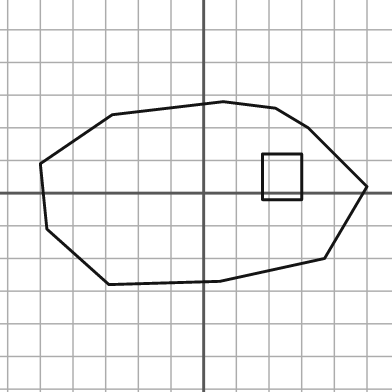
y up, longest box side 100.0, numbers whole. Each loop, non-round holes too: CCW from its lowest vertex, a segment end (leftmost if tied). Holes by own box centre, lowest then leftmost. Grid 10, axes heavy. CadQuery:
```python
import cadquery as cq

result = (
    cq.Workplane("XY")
    .moveTo(-29.0, -28.0)
    .lineTo(5.0, -27.0)
    .lineTo(37.0, -20.0)
    .lineTo(50.0, 2.0)
    .lineTo(32.0, 20.0)
    .lineTo(22.0, 26.0)
    .lineTo(6.0, 28.0)
    .lineTo(-28.0, 24.0)
    .lineTo(-50.0, 9.0)
    .lineTo(-48.0, -11.0)
    .close()
    .moveTo(18.0, -2.0)
    .lineTo(30.0, -2.0)
    .lineTo(30.0, 12.0)
    .lineTo(18.0, 12.0)
    .close()
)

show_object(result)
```